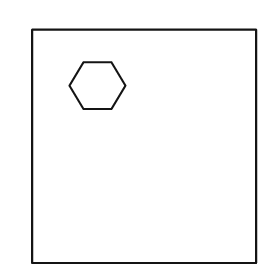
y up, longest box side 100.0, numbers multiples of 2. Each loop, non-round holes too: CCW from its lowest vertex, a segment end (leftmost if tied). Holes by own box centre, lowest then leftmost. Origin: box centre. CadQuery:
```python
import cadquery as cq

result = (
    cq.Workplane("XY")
    .moveTo(-48.0, -50.0)
    .lineTo(48.0, -50.0)
    .lineTo(48.0, 50.0)
    .lineTo(-48.0, 50.0)
    .close()
    .moveTo(-26.0, 16.0)
    .lineTo(-14.0, 16.0)
    .lineTo(-8.0, 26.0)
    .lineTo(-14.0, 36.0)
    .lineTo(-26.0, 36.0)
    .lineTo(-32.0, 26.0)
    .close()
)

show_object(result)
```